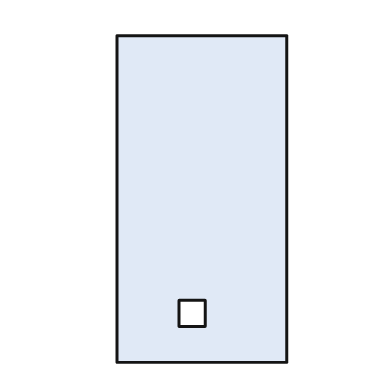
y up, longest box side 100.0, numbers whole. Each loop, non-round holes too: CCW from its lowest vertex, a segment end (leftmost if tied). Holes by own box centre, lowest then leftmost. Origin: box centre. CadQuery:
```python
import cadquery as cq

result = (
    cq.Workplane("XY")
    .moveTo(-26.0, -50.0)
    .lineTo(26.0, -50.0)
    .lineTo(26.0, 50.0)
    .lineTo(-26.0, 50.0)
    .close()
    .moveTo(-7.0, -39.0)
    .lineTo(1.0, -39.0)
    .lineTo(1.0, -31.0)
    .lineTo(-7.0, -31.0)
    .close()
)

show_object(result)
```